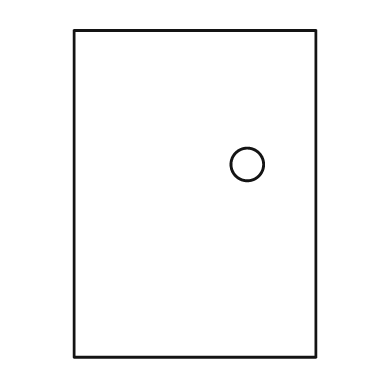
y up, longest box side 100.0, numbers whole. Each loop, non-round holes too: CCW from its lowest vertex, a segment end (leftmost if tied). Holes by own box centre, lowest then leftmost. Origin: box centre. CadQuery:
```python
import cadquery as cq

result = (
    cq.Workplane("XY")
    .moveTo(-37.0, -50.0)
    .lineTo(37.0, -50.0)
    .lineTo(37.0, 50.0)
    .lineTo(-37.0, 50.0)
    .close()
    .moveTo(16.0, 9.0)
    .circle(5.0)
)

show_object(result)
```